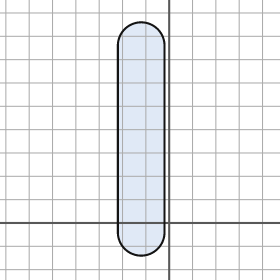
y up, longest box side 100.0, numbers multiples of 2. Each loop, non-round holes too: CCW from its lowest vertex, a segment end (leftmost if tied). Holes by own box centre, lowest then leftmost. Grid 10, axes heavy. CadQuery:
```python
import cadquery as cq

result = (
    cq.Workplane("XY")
    .moveTo(-22.0, -4.0)
    .threePointArc((-12.0, -14.0), (-2.0, -4.0))
    .lineTo(-2.0, 76.0)
    .threePointArc((-12.0, 86.0), (-22.0, 76.0))
    .close()
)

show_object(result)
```